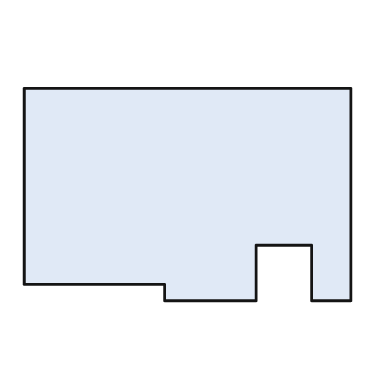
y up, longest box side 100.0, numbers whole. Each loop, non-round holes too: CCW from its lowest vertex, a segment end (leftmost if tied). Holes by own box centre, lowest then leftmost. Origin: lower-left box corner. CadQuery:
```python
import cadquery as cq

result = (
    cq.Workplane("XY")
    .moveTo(43.0, 0.0)
    .lineTo(71.0, 0.0)
    .lineTo(71.0, 17.0)
    .lineTo(88.0, 17.0)
    .lineTo(88.0, 0.0)
    .lineTo(100.0, 0.0)
    .lineTo(100.0, 65.0)
    .lineTo(0.0, 65.0)
    .lineTo(0.0, 5.0)
    .lineTo(43.0, 5.0)
    .close()
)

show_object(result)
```